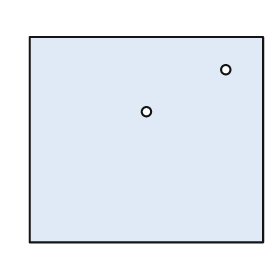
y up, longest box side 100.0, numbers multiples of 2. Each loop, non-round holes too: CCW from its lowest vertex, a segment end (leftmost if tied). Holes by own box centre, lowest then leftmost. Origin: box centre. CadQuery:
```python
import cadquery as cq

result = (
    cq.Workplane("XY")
    .moveTo(-50.0, -44.0)
    .lineTo(50.0, -44.0)
    .lineTo(50.0, 44.0)
    .lineTo(-50.0, 44.0)
    .close()
    .moveTo(0.0, 12.0)
    .circle(2.0)
    .moveTo(34.0, 30.0)
    .circle(2.0)
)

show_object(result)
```